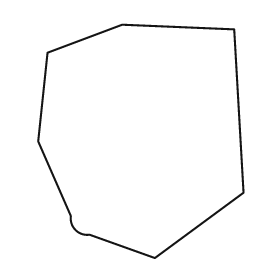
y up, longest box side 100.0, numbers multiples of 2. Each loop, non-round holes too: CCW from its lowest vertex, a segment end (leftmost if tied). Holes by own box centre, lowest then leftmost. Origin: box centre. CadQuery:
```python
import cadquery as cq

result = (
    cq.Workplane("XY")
    .moveTo(6.0, -50.0)
    .lineTo(44.0, -22.0)
    .lineTo(40.0, 48.0)
    .lineTo(-8.0, 50.0)
    .lineTo(-40.0, 38.0)
    .lineTo(-44.0, 0.0)
    .lineTo(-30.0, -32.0)
    .threePointArc((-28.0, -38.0), (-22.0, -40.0))
    .close()
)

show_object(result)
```